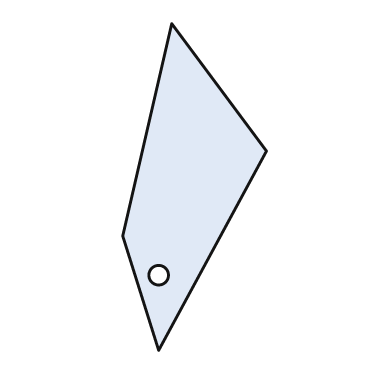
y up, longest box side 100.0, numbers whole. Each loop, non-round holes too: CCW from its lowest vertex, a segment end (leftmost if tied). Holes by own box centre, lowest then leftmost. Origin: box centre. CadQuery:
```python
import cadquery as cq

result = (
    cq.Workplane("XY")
    .moveTo(-11.0, -50.0)
    .lineTo(22.0, 11.0)
    .lineTo(-7.0, 50.0)
    .lineTo(-22.0, -15.0)
    .close()
    .moveTo(-11.0, -27.0)
    .circle(3.0)
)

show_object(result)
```